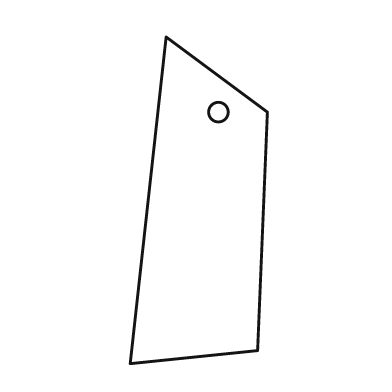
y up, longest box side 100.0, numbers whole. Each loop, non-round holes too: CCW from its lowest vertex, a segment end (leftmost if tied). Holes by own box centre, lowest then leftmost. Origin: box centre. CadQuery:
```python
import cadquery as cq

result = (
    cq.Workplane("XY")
    .moveTo(-21.0, -50.0)
    .lineTo(18.0, -46.0)
    .lineTo(21.0, 27.0)
    .lineTo(-10.0, 50.0)
    .close()
    .moveTo(6.0, 27.0)
    .circle(3.0)
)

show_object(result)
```